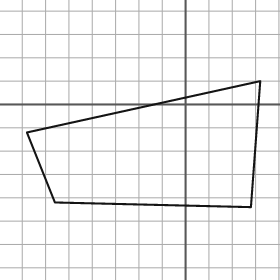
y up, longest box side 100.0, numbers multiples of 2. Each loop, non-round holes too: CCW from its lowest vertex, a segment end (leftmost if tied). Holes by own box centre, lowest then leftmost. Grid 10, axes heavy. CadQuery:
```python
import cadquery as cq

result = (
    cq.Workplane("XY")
    .moveTo(28.0, -44.0)
    .lineTo(32.0, 10.0)
    .lineTo(-68.0, -12.0)
    .lineTo(-56.0, -42.0)
    .close()
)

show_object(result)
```